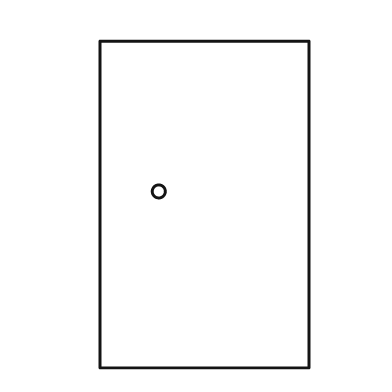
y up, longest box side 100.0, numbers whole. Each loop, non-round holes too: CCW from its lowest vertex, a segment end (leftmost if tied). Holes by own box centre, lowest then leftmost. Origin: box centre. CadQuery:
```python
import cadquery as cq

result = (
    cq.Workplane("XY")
    .moveTo(-32.0, -50.0)
    .lineTo(32.0, -50.0)
    .lineTo(32.0, 50.0)
    .lineTo(-32.0, 50.0)
    .close()
    .moveTo(-14.0, 4.0)
    .circle(2.0)
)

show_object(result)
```